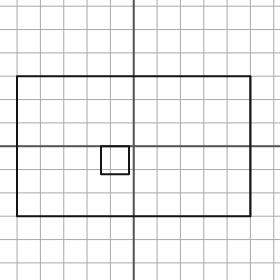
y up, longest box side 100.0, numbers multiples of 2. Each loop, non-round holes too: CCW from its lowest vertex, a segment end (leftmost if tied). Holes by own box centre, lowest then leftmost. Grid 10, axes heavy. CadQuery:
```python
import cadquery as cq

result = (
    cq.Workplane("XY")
    .moveTo(-50.0, -30.0)
    .lineTo(50.0, -30.0)
    .lineTo(50.0, 30.0)
    .lineTo(-50.0, 30.0)
    .close()
    .moveTo(-14.0, -12.0)
    .lineTo(-2.0, -12.0)
    .lineTo(-2.0, 0.0)
    .lineTo(-14.0, 0.0)
    .close()
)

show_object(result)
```